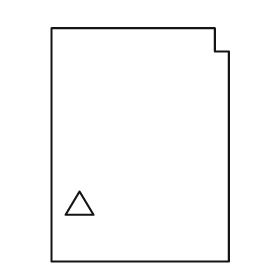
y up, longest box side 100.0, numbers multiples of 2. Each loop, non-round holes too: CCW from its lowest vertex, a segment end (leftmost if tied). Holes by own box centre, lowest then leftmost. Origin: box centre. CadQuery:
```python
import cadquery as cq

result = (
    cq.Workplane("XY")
    .moveTo(-38.0, -50.0)
    .lineTo(38.0, -50.0)
    .lineTo(38.0, 40.0)
    .lineTo(32.0, 40.0)
    .lineTo(32.0, 50.0)
    .lineTo(-38.0, 50.0)
    .close()
    .moveTo(-32.0, -30.0)
    .lineTo(-20.0, -30.0)
    .lineTo(-26.0, -20.0)
    .close()
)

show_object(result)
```